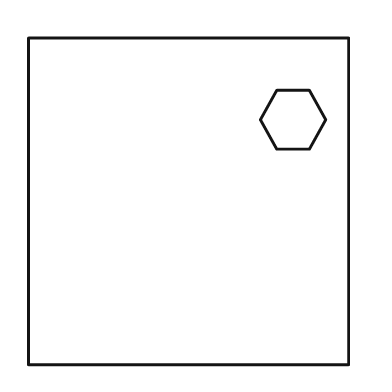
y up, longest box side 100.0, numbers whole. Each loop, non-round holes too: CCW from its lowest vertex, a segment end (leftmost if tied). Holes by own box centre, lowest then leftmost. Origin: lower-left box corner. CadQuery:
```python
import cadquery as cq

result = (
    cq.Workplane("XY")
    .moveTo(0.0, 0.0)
    .lineTo(98.0, 0.0)
    .lineTo(98.0, 100.0)
    .lineTo(0.0, 100.0)
    .close()
    .moveTo(76.0, 66.0)
    .lineTo(86.0, 66.0)
    .lineTo(91.0, 75.0)
    .lineTo(86.0, 84.0)
    .lineTo(76.0, 84.0)
    .lineTo(71.0, 75.0)
    .close()
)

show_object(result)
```